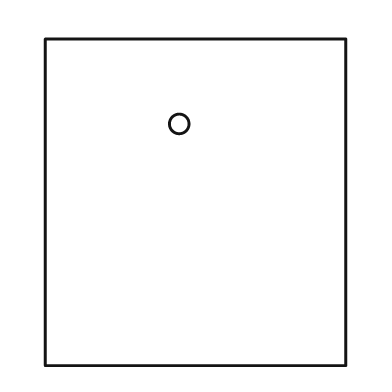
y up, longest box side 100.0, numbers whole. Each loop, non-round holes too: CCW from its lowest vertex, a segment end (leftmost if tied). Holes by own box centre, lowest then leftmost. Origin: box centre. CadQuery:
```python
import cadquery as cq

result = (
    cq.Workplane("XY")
    .moveTo(-46.0, -50.0)
    .lineTo(46.0, -50.0)
    .lineTo(46.0, 50.0)
    .lineTo(-46.0, 50.0)
    .close()
    .moveTo(-5.0, 24.0)
    .circle(3.0)
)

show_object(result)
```